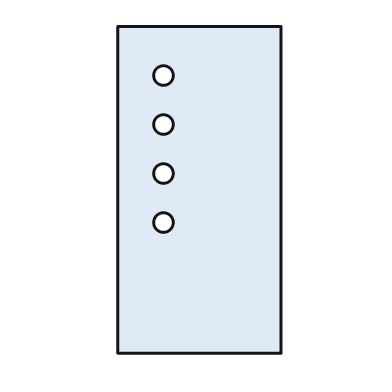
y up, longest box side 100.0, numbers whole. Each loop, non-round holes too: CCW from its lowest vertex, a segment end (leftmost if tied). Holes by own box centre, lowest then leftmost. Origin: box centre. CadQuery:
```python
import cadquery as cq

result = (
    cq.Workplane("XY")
    .moveTo(-25.0, -50.0)
    .lineTo(25.0, -50.0)
    .lineTo(25.0, 50.0)
    .lineTo(-25.0, 50.0)
    .close()
    .moveTo(-11.0, -10.0)
    .circle(3.0)
    .moveTo(-11.0, 5.0)
    .circle(3.0)
    .moveTo(-11.0, 20.0)
    .circle(3.0)
    .moveTo(-11.0, 35.0)
    .circle(3.0)
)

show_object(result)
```